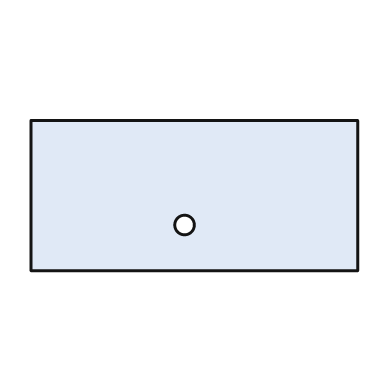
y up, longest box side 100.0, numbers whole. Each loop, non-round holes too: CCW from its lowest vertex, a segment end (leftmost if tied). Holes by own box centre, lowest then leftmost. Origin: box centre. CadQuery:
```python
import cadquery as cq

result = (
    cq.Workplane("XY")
    .moveTo(-50.0, -23.0)
    .lineTo(50.0, -23.0)
    .lineTo(50.0, 23.0)
    .lineTo(-50.0, 23.0)
    .close()
    .moveTo(-3.0, -9.0)
    .circle(3.0)
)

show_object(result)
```